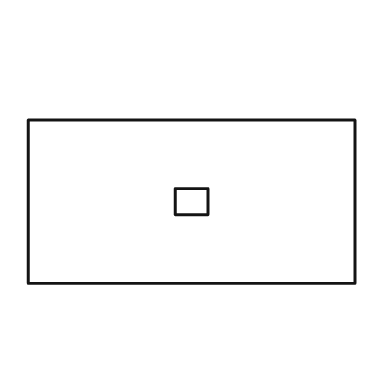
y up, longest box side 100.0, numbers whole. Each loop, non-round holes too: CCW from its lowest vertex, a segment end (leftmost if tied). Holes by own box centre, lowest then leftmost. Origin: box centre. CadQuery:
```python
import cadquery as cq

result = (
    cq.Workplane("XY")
    .moveTo(-50.0, -25.0)
    .lineTo(50.0, -25.0)
    .lineTo(50.0, 25.0)
    .lineTo(-50.0, 25.0)
    .close()
    .moveTo(-5.0, -4.0)
    .lineTo(5.0, -4.0)
    .lineTo(5.0, 4.0)
    .lineTo(-5.0, 4.0)
    .close()
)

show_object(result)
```